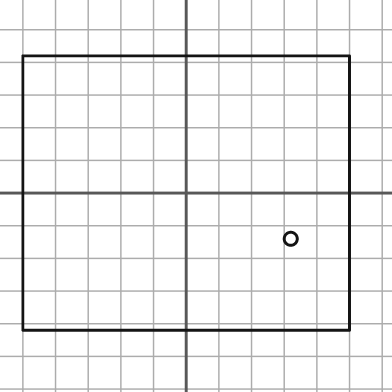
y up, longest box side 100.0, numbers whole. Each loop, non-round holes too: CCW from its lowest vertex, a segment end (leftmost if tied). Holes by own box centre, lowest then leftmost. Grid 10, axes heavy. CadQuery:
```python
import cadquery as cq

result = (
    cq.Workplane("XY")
    .moveTo(-50.0, -42.0)
    .lineTo(50.0, -42.0)
    .lineTo(50.0, 42.0)
    .lineTo(-50.0, 42.0)
    .close()
    .moveTo(32.0, -14.0)
    .circle(2.0)
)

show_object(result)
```